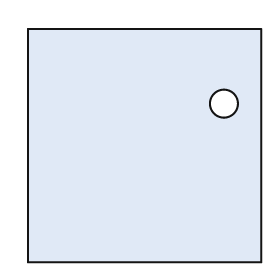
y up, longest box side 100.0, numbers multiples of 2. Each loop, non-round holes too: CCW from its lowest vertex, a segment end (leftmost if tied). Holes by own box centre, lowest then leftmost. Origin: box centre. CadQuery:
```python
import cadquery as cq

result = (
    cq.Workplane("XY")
    .moveTo(-50.0, -50.0)
    .lineTo(50.0, -50.0)
    .lineTo(50.0, 50.0)
    .lineTo(-50.0, 50.0)
    .close()
    .moveTo(34.0, 18.0)
    .circle(6.0)
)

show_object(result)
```